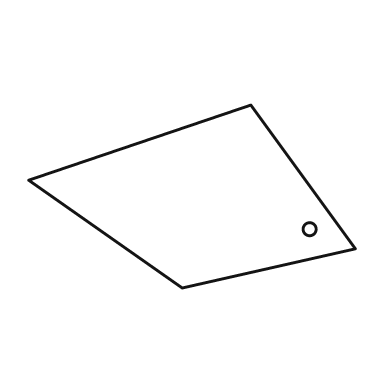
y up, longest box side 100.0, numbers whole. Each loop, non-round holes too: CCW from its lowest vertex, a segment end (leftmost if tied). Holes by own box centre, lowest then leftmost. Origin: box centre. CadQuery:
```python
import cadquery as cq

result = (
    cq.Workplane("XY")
    .moveTo(-3.0, -28.0)
    .lineTo(50.0, -16.0)
    .lineTo(18.0, 28.0)
    .lineTo(-50.0, 5.0)
    .close()
    .moveTo(36.0, -10.0)
    .circle(2.0)
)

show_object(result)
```